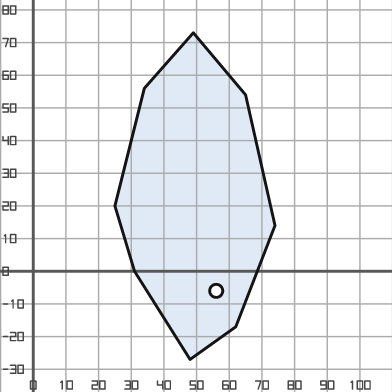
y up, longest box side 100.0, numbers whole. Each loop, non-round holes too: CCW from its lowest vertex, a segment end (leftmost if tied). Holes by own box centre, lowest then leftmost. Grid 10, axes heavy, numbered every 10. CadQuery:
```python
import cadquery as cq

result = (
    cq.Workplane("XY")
    .moveTo(48.0, -27.0)
    .lineTo(62.0, -17.0)
    .lineTo(74.0, 14.0)
    .lineTo(65.0, 54.0)
    .lineTo(49.0, 73.0)
    .lineTo(34.0, 56.0)
    .lineTo(25.0, 20.0)
    .lineTo(31.0, 0.0)
    .close()
    .moveTo(56.0, -6.0)
    .circle(2.0)
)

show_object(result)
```